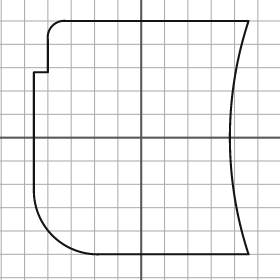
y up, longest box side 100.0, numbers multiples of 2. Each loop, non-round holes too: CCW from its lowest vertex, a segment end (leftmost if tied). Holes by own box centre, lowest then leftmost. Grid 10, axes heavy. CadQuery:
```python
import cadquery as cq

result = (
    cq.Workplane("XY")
    .moveTo(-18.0, -50.0)
    .lineTo(46.0, -50.0)
    .threePointArc((38.0, 0.0), (46.0, 50.0))
    .lineTo(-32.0, 50.0)
    .threePointArc((-38.0, 48.0), (-40.0, 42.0))
    .lineTo(-40.0, 28.0)
    .lineTo(-46.0, 28.0)
    .lineTo(-46.0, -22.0)
    .threePointArc((-38.0, -42.0), (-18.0, -50.0))
    .close()
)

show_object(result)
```